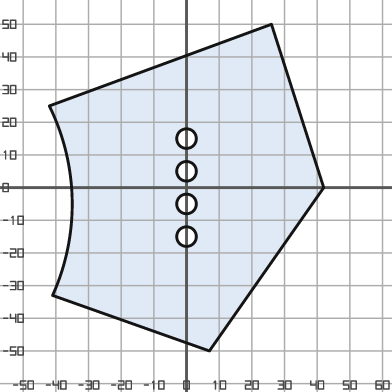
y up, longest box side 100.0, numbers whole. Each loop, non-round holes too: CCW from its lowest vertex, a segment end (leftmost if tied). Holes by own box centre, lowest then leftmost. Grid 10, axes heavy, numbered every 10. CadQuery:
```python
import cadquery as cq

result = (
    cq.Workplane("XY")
    .moveTo(7.0, -50.0)
    .lineTo(42.0, 0.0)
    .lineTo(26.0, 50.0)
    .lineTo(-42.0, 25.0)
    .threePointArc((-35.0, -4.0), (-41.0, -33.0))
    .close()
    .moveTo(0.0, -15.0)
    .circle(3.0)
    .moveTo(0.0, -5.0)
    .circle(3.0)
    .moveTo(0.0, 5.0)
    .circle(3.0)
    .moveTo(0.0, 15.0)
    .circle(3.0)
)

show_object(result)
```